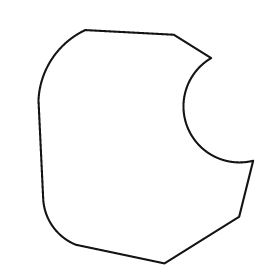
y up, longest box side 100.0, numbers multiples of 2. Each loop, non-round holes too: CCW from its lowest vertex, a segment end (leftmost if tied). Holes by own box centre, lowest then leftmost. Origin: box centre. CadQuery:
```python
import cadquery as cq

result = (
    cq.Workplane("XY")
    .moveTo(8.0, -50.0)
    .lineTo(40.0, -30.0)
    .lineTo(46.0, -6.0)
    .threePointArc((18.0, 8.0), (28.0, 38.0))
    .lineTo(12.0, 48.0)
    .lineTo(-26.0, 50.0)
    .threePointArc((-40.0, 38.0), (-46.0, 20.0))
    .lineTo(-44.0, -22.0)
    .threePointArc((-40.0, -34.0), (-30.0, -42.0))
    .close()
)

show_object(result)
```